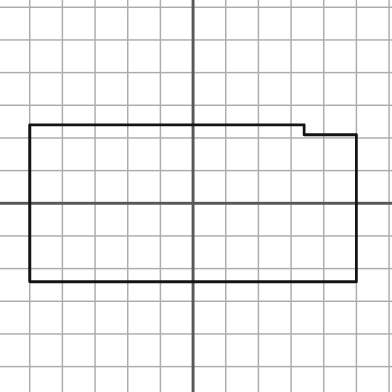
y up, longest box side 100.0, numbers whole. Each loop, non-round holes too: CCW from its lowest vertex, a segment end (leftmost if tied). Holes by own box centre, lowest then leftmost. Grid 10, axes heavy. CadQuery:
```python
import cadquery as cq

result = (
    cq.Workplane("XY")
    .moveTo(-50.0, -24.0)
    .lineTo(50.0, -24.0)
    .lineTo(50.0, 21.0)
    .lineTo(34.0, 21.0)
    .lineTo(34.0, 24.0)
    .lineTo(-50.0, 24.0)
    .close()
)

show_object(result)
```